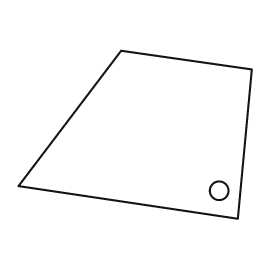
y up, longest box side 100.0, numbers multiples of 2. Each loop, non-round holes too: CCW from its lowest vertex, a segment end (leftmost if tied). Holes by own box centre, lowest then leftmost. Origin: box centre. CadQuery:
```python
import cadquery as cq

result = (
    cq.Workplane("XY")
    .moveTo(44.0, -36.0)
    .lineTo(50.0, 28.0)
    .lineTo(-6.0, 36.0)
    .lineTo(-50.0, -22.0)
    .close()
    .moveTo(36.0, -24.0)
    .circle(4.0)
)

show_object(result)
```